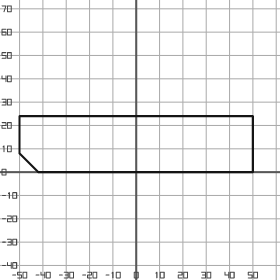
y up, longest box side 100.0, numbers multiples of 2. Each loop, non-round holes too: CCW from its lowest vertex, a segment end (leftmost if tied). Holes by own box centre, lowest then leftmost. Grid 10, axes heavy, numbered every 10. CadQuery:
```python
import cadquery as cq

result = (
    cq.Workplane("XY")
    .moveTo(-42.0, 0.0)
    .lineTo(50.0, 0.0)
    .lineTo(50.0, 24.0)
    .lineTo(-50.0, 24.0)
    .lineTo(-50.0, 8.0)
    .close()
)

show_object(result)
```